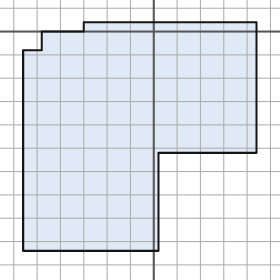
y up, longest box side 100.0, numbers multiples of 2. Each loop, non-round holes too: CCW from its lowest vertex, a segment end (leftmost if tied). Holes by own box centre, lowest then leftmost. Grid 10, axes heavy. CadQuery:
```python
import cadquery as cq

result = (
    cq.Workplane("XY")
    .moveTo(-56.0, -94.0)
    .lineTo(2.0, -94.0)
    .lineTo(2.0, -52.0)
    .lineTo(44.0, -52.0)
    .lineTo(44.0, 4.0)
    .lineTo(-30.0, 4.0)
    .lineTo(-30.0, 0.0)
    .lineTo(-48.0, 0.0)
    .lineTo(-48.0, -8.0)
    .lineTo(-56.0, -8.0)
    .close()
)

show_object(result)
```